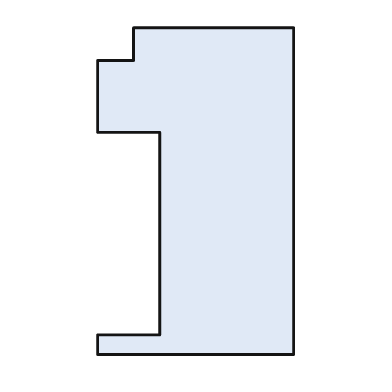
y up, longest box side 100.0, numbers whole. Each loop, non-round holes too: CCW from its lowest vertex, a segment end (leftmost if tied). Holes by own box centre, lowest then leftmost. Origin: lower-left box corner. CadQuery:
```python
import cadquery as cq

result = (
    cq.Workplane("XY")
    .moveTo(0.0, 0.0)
    .lineTo(60.0, 0.0)
    .lineTo(60.0, 100.0)
    .lineTo(11.0, 100.0)
    .lineTo(11.0, 90.0)
    .lineTo(0.0, 90.0)
    .lineTo(0.0, 68.0)
    .lineTo(19.0, 68.0)
    .lineTo(19.0, 6.0)
    .lineTo(0.0, 6.0)
    .close()
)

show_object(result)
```